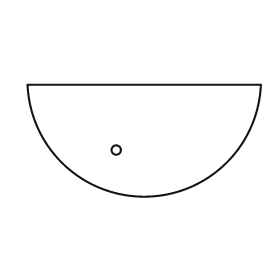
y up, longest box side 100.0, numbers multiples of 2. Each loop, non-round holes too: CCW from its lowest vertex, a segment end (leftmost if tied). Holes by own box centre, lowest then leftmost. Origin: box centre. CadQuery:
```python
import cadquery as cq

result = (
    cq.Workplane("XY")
    .moveTo(-50.0, 24.0)
    .threePointArc((0.0, -24.0), (50.0, 24.0))
    .close()
    .moveTo(-12.0, -4.0)
    .circle(2.0)
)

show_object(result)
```